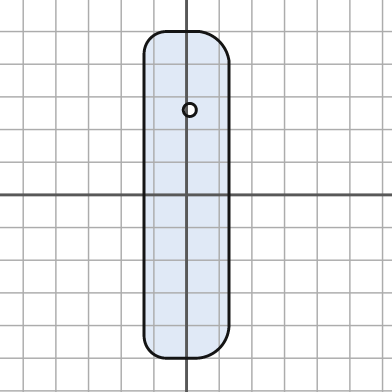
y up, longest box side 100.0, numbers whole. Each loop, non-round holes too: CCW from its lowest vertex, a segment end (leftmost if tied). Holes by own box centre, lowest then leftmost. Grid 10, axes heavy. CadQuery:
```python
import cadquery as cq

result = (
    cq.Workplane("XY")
    .moveTo(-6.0, -50.0)
    .lineTo(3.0, -50.0)
    .threePointArc((10.0, -47.0), (13.0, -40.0))
    .lineTo(13.0, 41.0)
    .threePointArc((10.0, 47.0), (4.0, 50.0))
    .lineTo(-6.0, 50.0)
    .threePointArc((-11.0, 48.0), (-13.0, 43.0))
    .lineTo(-13.0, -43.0)
    .threePointArc((-11.0, -48.0), (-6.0, -50.0))
    .close()
    .moveTo(1.0, 26.0)
    .circle(2.0)
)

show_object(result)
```